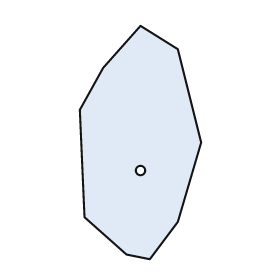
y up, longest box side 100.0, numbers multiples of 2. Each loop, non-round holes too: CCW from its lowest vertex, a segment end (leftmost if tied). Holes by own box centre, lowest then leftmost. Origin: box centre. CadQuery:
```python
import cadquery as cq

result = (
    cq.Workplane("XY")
    .moveTo(4.0, -50.0)
    .lineTo(16.0, -34.0)
    .lineTo(26.0, 0.0)
    .lineTo(16.0, 40.0)
    .lineTo(0.0, 50.0)
    .lineTo(-16.0, 32.0)
    .lineTo(-26.0, 14.0)
    .lineTo(-24.0, -32.0)
    .lineTo(-6.0, -48.0)
    .close()
    .moveTo(0.0, -12.0)
    .circle(2.0)
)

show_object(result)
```